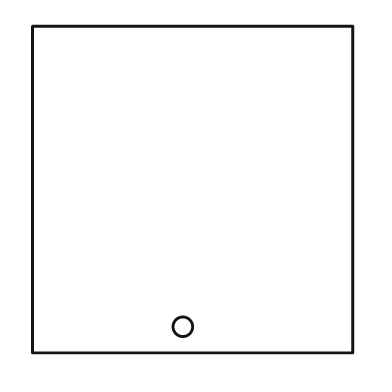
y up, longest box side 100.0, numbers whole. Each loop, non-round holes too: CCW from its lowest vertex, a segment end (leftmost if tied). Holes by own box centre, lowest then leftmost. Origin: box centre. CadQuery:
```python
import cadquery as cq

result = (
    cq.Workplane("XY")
    .moveTo(-49.0, -50.0)
    .lineTo(49.0, -50.0)
    .lineTo(49.0, 50.0)
    .lineTo(-49.0, 50.0)
    .close()
    .moveTo(-3.0, -42.0)
    .circle(3.0)
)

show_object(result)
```